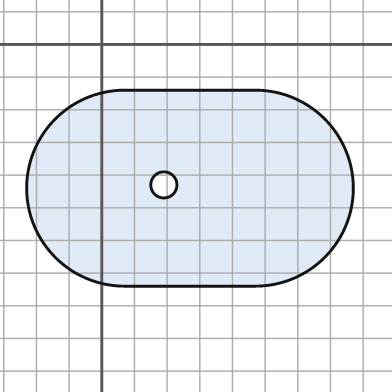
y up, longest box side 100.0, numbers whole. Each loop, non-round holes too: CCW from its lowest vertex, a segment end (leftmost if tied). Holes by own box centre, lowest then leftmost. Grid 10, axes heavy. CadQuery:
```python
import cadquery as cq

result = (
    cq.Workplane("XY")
    .moveTo(7.0, -74.0)
    .lineTo(47.0, -74.0)
    .threePointArc((77.0, -44.0), (47.0, -14.0))
    .lineTo(7.0, -14.0)
    .threePointArc((-23.0, -44.0), (7.0, -74.0))
    .close()
    .moveTo(19.0, -43.0)
    .circle(4.0)
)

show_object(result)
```